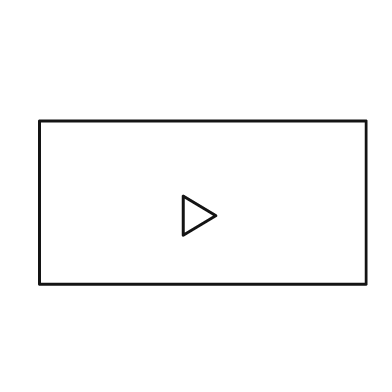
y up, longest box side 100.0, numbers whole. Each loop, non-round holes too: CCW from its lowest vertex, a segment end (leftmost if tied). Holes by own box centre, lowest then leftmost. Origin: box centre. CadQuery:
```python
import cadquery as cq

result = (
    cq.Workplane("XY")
    .moveTo(-50.0, -25.0)
    .lineTo(50.0, -25.0)
    .lineTo(50.0, 25.0)
    .lineTo(-50.0, 25.0)
    .close()
    .moveTo(-6.0, -10.0)
    .lineTo(4.0, -4.0)
    .lineTo(-6.0, 2.0)
    .close()
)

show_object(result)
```